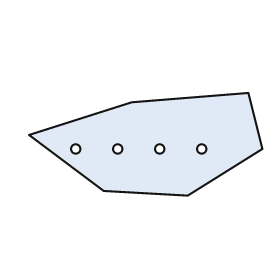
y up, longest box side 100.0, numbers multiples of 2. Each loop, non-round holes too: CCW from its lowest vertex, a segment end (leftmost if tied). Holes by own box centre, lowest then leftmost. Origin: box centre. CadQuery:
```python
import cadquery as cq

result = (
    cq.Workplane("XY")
    .moveTo(18.0, -22.0)
    .lineTo(50.0, -2.0)
    .lineTo(44.0, 22.0)
    .lineTo(-6.0, 18.0)
    .lineTo(-50.0, 4.0)
    .lineTo(-18.0, -20.0)
    .close()
    .moveTo(-30.0, -2.0)
    .circle(2.0)
    .moveTo(-12.0, -2.0)
    .circle(2.0)
    .moveTo(6.0, -2.0)
    .circle(2.0)
    .moveTo(24.0, -2.0)
    .circle(2.0)
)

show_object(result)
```